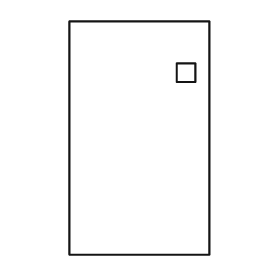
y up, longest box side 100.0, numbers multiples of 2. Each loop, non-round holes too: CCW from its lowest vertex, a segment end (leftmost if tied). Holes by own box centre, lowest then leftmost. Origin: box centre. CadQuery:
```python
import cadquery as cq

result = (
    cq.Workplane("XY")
    .moveTo(-30.0, -50.0)
    .lineTo(30.0, -50.0)
    .lineTo(30.0, 50.0)
    .lineTo(-30.0, 50.0)
    .close()
    .moveTo(16.0, 24.0)
    .lineTo(24.0, 24.0)
    .lineTo(24.0, 32.0)
    .lineTo(16.0, 32.0)
    .close()
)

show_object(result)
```